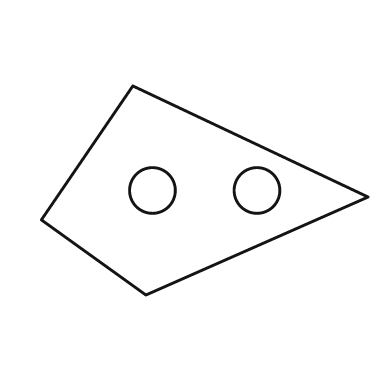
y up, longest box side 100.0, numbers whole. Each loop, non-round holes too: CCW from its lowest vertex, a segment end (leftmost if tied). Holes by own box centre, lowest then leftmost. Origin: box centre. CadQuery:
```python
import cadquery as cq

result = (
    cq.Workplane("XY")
    .moveTo(-18.0, -32.0)
    .lineTo(50.0, -2.0)
    .lineTo(-22.0, 32.0)
    .lineTo(-50.0, -9.0)
    .close()
    .moveTo(-16.0, 0.0)
    .circle(7.0)
    .moveTo(16.0, 0.0)
    .circle(7.0)
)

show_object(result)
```